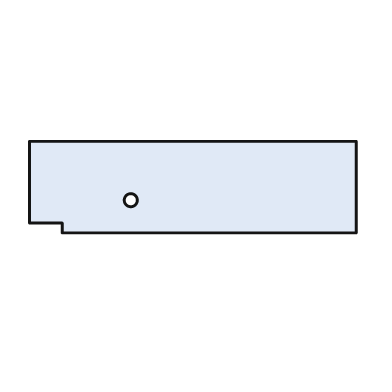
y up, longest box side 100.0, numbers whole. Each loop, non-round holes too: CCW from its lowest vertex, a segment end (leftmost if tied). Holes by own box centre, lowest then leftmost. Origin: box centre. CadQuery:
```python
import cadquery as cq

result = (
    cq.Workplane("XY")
    .moveTo(-40.0, -14.0)
    .lineTo(50.0, -14.0)
    .lineTo(50.0, 14.0)
    .lineTo(-50.0, 14.0)
    .lineTo(-50.0, -11.0)
    .lineTo(-40.0, -11.0)
    .close()
    .moveTo(-19.0, -4.0)
    .circle(2.0)
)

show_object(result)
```